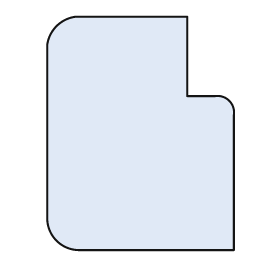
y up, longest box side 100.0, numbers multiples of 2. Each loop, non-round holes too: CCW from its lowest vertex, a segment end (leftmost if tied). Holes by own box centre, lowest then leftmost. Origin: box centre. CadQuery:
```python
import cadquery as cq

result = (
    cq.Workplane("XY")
    .moveTo(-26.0, -50.0)
    .lineTo(40.0, -50.0)
    .lineTo(40.0, 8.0)
    .threePointArc((38.0, 14.0), (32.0, 16.0))
    .lineTo(20.0, 16.0)
    .lineTo(20.0, 50.0)
    .lineTo(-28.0, 50.0)
    .threePointArc((-36.0, 46.0), (-40.0, 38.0))
    .lineTo(-40.0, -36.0)
    .threePointArc((-36.0, -46.0), (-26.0, -50.0))
    .close()
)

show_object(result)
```